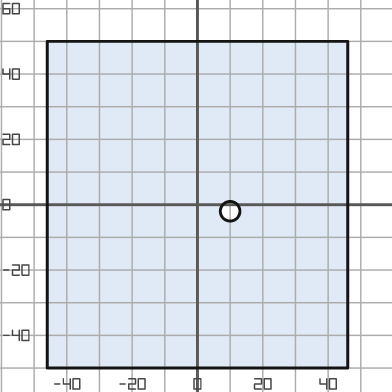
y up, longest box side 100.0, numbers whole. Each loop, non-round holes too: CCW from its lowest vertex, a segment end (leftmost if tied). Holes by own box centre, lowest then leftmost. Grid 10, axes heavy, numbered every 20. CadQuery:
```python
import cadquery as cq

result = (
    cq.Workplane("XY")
    .moveTo(-46.0, -50.0)
    .lineTo(46.0, -50.0)
    .lineTo(46.0, 50.0)
    .lineTo(-46.0, 50.0)
    .close()
    .moveTo(10.0, -2.0)
    .circle(3.0)
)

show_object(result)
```